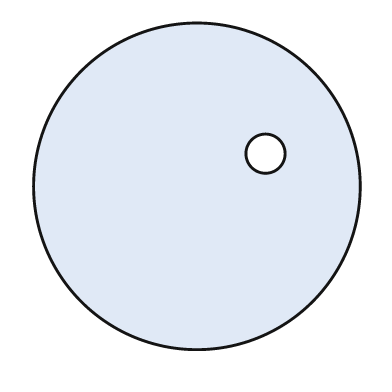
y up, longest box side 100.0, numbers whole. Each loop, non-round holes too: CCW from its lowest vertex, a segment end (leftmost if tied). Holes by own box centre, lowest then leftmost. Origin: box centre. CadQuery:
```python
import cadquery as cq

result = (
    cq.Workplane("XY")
    .moveTo(0.0, 0.0)
    .circle(50.0)
    .moveTo(21.0, 10.0)
    .circle(6.0)
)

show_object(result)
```